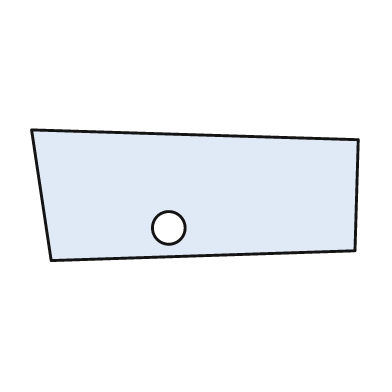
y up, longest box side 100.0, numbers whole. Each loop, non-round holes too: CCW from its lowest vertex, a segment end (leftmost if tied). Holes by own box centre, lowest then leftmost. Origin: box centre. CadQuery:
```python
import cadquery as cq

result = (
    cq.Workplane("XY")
    .moveTo(-44.0, -20.0)
    .lineTo(49.0, -17.0)
    .lineTo(50.0, 17.0)
    .lineTo(-50.0, 20.0)
    .close()
    .moveTo(-8.0, -10.0)
    .circle(5.0)
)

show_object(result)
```